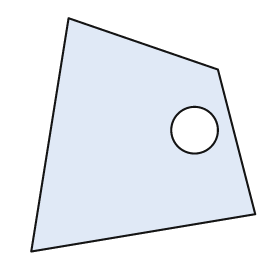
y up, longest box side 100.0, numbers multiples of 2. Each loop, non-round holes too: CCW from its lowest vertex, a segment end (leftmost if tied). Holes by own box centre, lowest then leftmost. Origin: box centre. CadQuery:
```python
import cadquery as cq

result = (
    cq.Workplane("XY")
    .moveTo(-48.0, -50.0)
    .lineTo(48.0, -34.0)
    .lineTo(32.0, 28.0)
    .lineTo(-32.0, 50.0)
    .close()
    .moveTo(22.0, 2.0)
    .circle(10.0)
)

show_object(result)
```